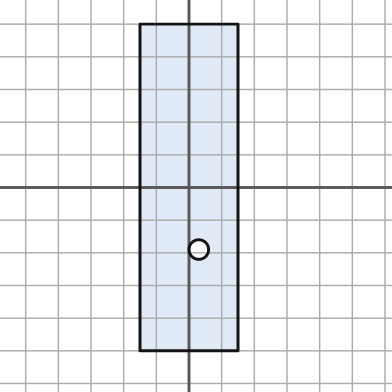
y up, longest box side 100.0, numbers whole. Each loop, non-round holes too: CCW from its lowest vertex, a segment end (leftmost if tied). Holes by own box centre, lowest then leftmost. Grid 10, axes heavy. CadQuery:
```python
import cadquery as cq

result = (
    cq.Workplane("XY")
    .moveTo(-15.0, -50.0)
    .lineTo(15.0, -50.0)
    .lineTo(15.0, 50.0)
    .lineTo(-15.0, 50.0)
    .close()
    .moveTo(3.0, -19.0)
    .circle(3.0)
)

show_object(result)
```